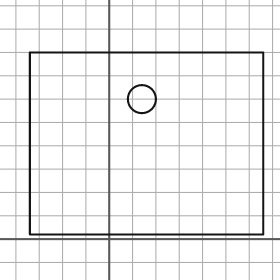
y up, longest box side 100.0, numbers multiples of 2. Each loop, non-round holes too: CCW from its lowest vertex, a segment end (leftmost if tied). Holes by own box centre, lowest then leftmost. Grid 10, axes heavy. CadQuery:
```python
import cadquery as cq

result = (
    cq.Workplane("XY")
    .moveTo(-34.0, 2.0)
    .lineTo(66.0, 2.0)
    .lineTo(66.0, 80.0)
    .lineTo(-34.0, 80.0)
    .close()
    .moveTo(14.0, 60.0)
    .circle(6.0)
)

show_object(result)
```